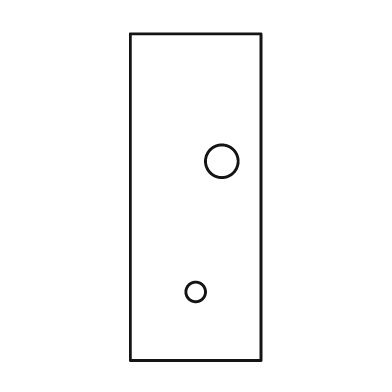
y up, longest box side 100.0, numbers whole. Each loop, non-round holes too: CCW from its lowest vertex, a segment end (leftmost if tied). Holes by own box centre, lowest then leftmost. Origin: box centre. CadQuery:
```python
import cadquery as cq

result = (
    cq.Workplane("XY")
    .moveTo(-20.0, -50.0)
    .lineTo(20.0, -50.0)
    .lineTo(20.0, 50.0)
    .lineTo(-20.0, 50.0)
    .close()
    .moveTo(0.0, -29.0)
    .circle(3.0)
    .moveTo(8.0, 11.0)
    .circle(5.0)
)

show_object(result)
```